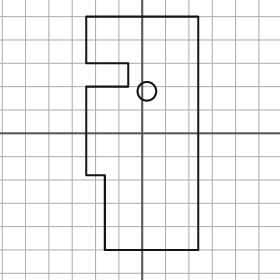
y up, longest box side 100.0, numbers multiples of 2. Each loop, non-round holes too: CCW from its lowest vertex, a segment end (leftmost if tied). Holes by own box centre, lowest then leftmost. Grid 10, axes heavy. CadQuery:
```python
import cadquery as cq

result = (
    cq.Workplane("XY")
    .moveTo(-16.0, -50.0)
    .lineTo(24.0, -50.0)
    .lineTo(24.0, 50.0)
    .lineTo(-24.0, 50.0)
    .lineTo(-24.0, 30.0)
    .lineTo(-6.0, 30.0)
    .lineTo(-6.0, 20.0)
    .lineTo(-24.0, 20.0)
    .lineTo(-24.0, -18.0)
    .lineTo(-16.0, -18.0)
    .close()
    .moveTo(2.0, 18.0)
    .circle(4.0)
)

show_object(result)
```